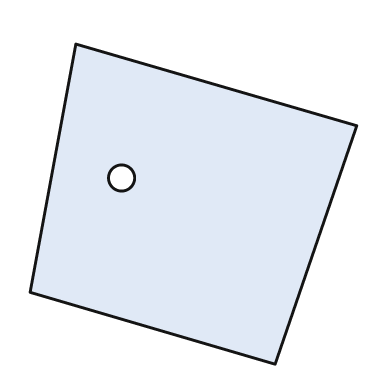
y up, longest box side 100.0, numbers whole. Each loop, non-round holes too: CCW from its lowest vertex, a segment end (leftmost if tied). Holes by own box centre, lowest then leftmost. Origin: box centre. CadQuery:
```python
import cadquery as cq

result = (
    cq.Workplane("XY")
    .moveTo(25.0, -49.0)
    .lineTo(50.0, 24.0)
    .lineTo(-36.0, 49.0)
    .lineTo(-50.0, -27.0)
    .close()
    .moveTo(-22.0, 8.0)
    .circle(4.0)
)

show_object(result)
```